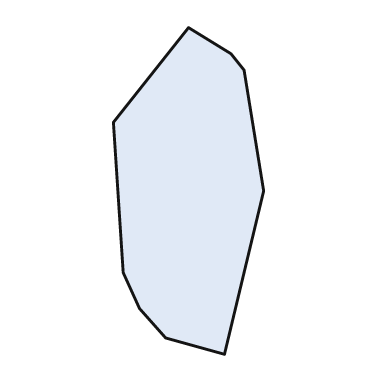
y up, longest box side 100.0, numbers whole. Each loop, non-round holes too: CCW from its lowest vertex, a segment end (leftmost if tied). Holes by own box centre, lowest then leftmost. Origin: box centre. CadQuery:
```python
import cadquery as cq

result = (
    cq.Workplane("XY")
    .moveTo(11.0, -50.0)
    .lineTo(23.0, 0.0)
    .lineTo(17.0, 37.0)
    .lineTo(13.0, 42.0)
    .lineTo(0.0, 50.0)
    .lineTo(-23.0, 21.0)
    .lineTo(-20.0, -25.0)
    .lineTo(-15.0, -36.0)
    .lineTo(-7.0, -45.0)
    .close()
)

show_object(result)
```